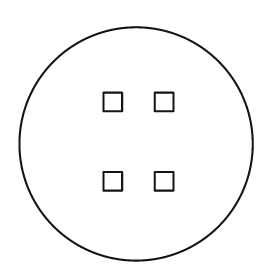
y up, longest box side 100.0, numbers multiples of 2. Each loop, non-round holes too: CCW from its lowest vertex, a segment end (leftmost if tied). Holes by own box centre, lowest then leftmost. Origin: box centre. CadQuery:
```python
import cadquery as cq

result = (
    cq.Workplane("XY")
    .moveTo(0.0, 0.0)
    .circle(50.0)
    .moveTo(-14.0, -20.0)
    .lineTo(-6.0, -20.0)
    .lineTo(-6.0, -12.0)
    .lineTo(-14.0, -12.0)
    .close()
    .moveTo(8.0, -20.0)
    .lineTo(16.0, -20.0)
    .lineTo(16.0, -12.0)
    .lineTo(8.0, -12.0)
    .close()
    .moveTo(-14.0, 14.0)
    .lineTo(-6.0, 14.0)
    .lineTo(-6.0, 22.0)
    .lineTo(-14.0, 22.0)
    .close()
    .moveTo(8.0, 14.0)
    .lineTo(16.0, 14.0)
    .lineTo(16.0, 22.0)
    .lineTo(8.0, 22.0)
    .close()
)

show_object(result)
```